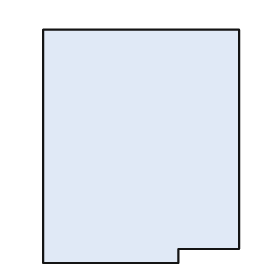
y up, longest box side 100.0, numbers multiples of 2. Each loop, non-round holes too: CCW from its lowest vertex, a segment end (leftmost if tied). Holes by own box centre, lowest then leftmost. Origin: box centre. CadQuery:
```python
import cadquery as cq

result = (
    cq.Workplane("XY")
    .moveTo(-42.0, -50.0)
    .lineTo(16.0, -50.0)
    .lineTo(16.0, -44.0)
    .lineTo(42.0, -44.0)
    .lineTo(42.0, 50.0)
    .lineTo(-42.0, 50.0)
    .close()
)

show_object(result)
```